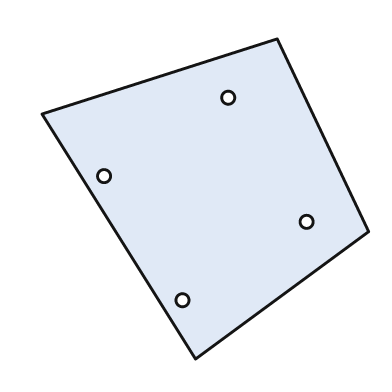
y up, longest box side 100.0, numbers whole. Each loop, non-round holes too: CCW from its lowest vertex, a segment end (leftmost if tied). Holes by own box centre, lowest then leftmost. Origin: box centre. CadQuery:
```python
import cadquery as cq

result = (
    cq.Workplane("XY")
    .moveTo(-3.0, -49.0)
    .lineTo(50.0, -10.0)
    .lineTo(22.0, 49.0)
    .lineTo(-50.0, 26.0)
    .close()
    .moveTo(-7.0, -31.0)
    .circle(2.0)
    .moveTo(31.0, -7.0)
    .circle(2.0)
    .moveTo(-31.0, 7.0)
    .circle(2.0)
    .moveTo(7.0, 31.0)
    .circle(2.0)
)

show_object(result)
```